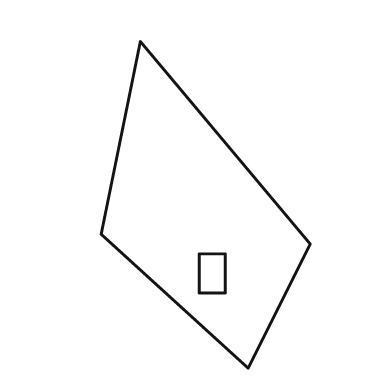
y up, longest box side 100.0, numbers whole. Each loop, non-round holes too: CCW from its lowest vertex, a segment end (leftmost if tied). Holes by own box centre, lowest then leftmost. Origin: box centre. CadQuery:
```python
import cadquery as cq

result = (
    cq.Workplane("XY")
    .moveTo(13.0, -50.0)
    .lineTo(32.0, -12.0)
    .lineTo(-20.0, 50.0)
    .lineTo(-32.0, -9.0)
    .close()
    .moveTo(-2.0, -27.0)
    .lineTo(6.0, -27.0)
    .lineTo(6.0, -15.0)
    .lineTo(-2.0, -15.0)
    .close()
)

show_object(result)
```